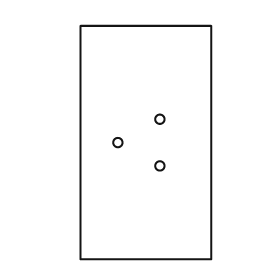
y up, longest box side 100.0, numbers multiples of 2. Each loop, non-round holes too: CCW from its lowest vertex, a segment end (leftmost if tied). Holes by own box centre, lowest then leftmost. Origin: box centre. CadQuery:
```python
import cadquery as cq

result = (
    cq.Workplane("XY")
    .moveTo(-28.0, -50.0)
    .lineTo(28.0, -50.0)
    .lineTo(28.0, 50.0)
    .lineTo(-28.0, 50.0)
    .close()
    .moveTo(6.0, -10.0)
    .circle(2.0)
    .moveTo(-12.0, 0.0)
    .circle(2.0)
    .moveTo(6.0, 10.0)
    .circle(2.0)
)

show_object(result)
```